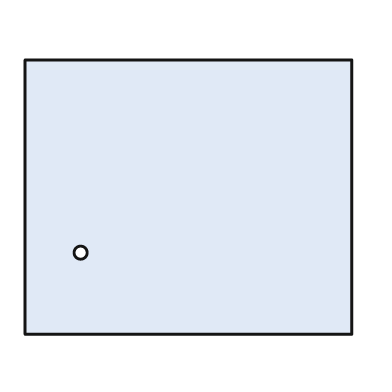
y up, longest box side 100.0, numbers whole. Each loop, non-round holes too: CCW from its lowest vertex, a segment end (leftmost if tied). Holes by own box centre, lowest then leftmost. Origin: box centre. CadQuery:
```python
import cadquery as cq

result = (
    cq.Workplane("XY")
    .moveTo(-50.0, -42.0)
    .lineTo(50.0, -42.0)
    .lineTo(50.0, 42.0)
    .lineTo(-50.0, 42.0)
    .close()
    .moveTo(-33.0, -17.0)
    .circle(2.0)
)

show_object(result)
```